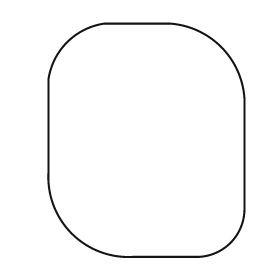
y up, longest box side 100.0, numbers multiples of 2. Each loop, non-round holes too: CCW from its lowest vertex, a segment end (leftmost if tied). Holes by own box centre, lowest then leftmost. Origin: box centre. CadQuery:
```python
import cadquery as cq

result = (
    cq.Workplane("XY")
    .moveTo(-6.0, -50.0)
    .lineTo(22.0, -50.0)
    .threePointArc((36.0, -44.0), (42.0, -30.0))
    .lineTo(42.0, 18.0)
    .threePointArc((32.0, 40.0), (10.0, 50.0))
    .lineTo(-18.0, 50.0)
    .threePointArc((-34.0, 42.0), (-42.0, 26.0))
    .lineTo(-42.0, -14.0)
    .threePointArc((-32.0, -40.0), (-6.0, -50.0))
    .close()
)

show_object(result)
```